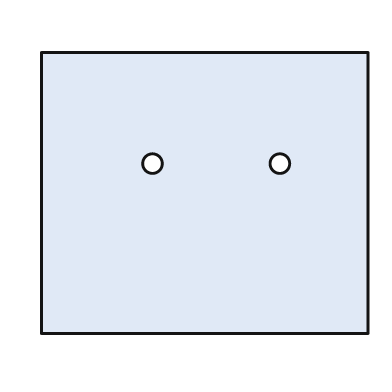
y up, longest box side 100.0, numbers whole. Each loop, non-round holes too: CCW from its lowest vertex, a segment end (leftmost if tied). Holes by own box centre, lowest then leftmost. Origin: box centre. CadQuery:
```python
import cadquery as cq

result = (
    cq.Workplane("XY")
    .moveTo(-50.0, -43.0)
    .lineTo(50.0, -43.0)
    .lineTo(50.0, 43.0)
    .lineTo(-50.0, 43.0)
    .close()
    .moveTo(-16.0, 9.0)
    .circle(3.0)
    .moveTo(23.0, 9.0)
    .circle(3.0)
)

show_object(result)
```